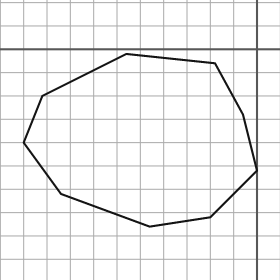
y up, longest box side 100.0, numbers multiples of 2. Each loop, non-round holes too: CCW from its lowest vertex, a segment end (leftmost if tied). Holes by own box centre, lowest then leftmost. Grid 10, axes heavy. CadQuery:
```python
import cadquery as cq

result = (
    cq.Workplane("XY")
    .moveTo(-46.0, -76.0)
    .lineTo(-20.0, -72.0)
    .lineTo(0.0, -52.0)
    .lineTo(-6.0, -28.0)
    .lineTo(-18.0, -6.0)
    .lineTo(-56.0, -2.0)
    .lineTo(-92.0, -20.0)
    .lineTo(-100.0, -40.0)
    .lineTo(-84.0, -62.0)
    .close()
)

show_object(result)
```